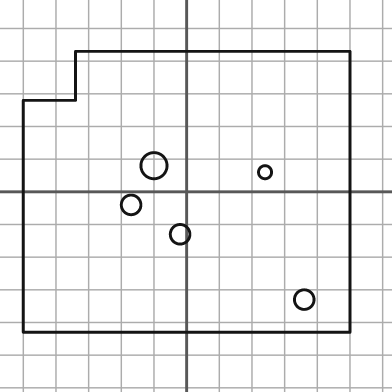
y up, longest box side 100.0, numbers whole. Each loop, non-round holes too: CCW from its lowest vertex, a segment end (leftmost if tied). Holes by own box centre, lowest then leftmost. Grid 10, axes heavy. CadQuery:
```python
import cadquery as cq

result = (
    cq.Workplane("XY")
    .moveTo(-50.0, -43.0)
    .lineTo(50.0, -43.0)
    .lineTo(50.0, 43.0)
    .lineTo(-34.0, 43.0)
    .lineTo(-34.0, 28.0)
    .lineTo(-50.0, 28.0)
    .close()
    .moveTo(36.0, -33.0)
    .circle(3.0)
    .moveTo(-2.0, -13.0)
    .circle(3.0)
    .moveTo(-17.0, -4.0)
    .circle(3.0)
    .moveTo(24.0, 6.0)
    .circle(2.0)
    .moveTo(-10.0, 8.0)
    .circle(4.0)
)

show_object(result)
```